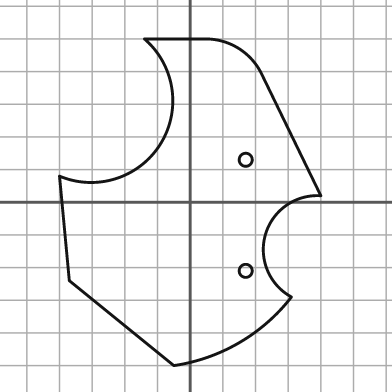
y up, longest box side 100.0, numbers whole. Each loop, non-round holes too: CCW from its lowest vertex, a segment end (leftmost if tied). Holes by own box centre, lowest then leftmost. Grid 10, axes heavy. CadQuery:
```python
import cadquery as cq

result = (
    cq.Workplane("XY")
    .moveTo(-5.0, -50.0)
    .threePointArc((15.0, -43.0), (31.0, -29.0))
    .threePointArc((23.0, -10.0), (40.0, 2.0))
    .lineTo(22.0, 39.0)
    .threePointArc((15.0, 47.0), (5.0, 50.0))
    .lineTo(-14.0, 50.0)
    .threePointArc((-9.0, 18.0), (-40.0, 8.0))
    .lineTo(-37.0, -24.0)
    .close()
    .moveTo(17.0, -21.0)
    .circle(2.0)
    .moveTo(17.0, 13.0)
    .circle(2.0)
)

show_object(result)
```